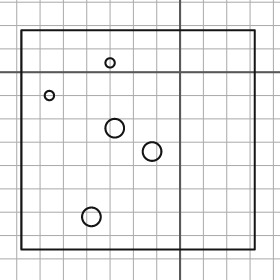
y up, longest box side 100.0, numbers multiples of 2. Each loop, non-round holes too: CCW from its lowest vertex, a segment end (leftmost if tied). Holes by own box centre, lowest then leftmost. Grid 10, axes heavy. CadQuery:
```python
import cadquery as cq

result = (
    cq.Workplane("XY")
    .moveTo(-68.0, -76.0)
    .lineTo(32.0, -76.0)
    .lineTo(32.0, 18.0)
    .lineTo(-68.0, 18.0)
    .close()
    .moveTo(-38.0, -62.0)
    .circle(4.0)
    .moveTo(-12.0, -34.0)
    .circle(4.0)
    .moveTo(-28.0, -24.0)
    .circle(4.0)
    .moveTo(-56.0, -10.0)
    .circle(2.0)
    .moveTo(-30.0, 4.0)
    .circle(2.0)
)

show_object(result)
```